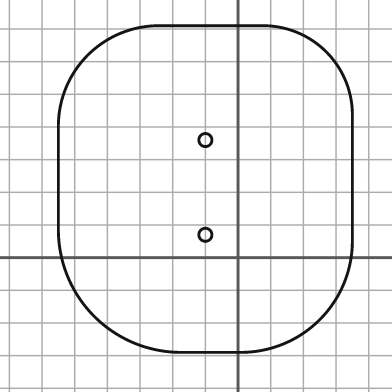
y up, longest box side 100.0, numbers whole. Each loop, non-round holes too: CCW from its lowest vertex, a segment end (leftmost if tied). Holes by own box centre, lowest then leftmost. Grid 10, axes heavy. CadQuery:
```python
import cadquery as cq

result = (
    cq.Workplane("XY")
    .moveTo(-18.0, -29.0)
    .lineTo(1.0, -29.0)
    .threePointArc((25.0, -19.0), (35.0, 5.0))
    .lineTo(35.0, 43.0)
    .threePointArc((27.0, 63.0), (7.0, 71.0))
    .lineTo(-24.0, 71.0)
    .threePointArc((-46.0, 62.0), (-55.0, 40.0))
    .lineTo(-55.0, 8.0)
    .threePointArc((-44.0, -18.0), (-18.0, -29.0))
    .close()
    .moveTo(-10.0, 7.0)
    .circle(2.0)
    .moveTo(-10.0, 36.0)
    .circle(2.0)
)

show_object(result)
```